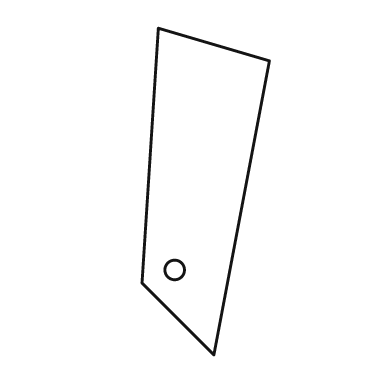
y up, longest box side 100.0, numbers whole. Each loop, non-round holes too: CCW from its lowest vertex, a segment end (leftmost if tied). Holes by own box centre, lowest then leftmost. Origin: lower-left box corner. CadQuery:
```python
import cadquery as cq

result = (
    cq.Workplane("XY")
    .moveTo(22.0, 0.0)
    .lineTo(39.0, 90.0)
    .lineTo(5.0, 100.0)
    .lineTo(0.0, 22.0)
    .close()
    .moveTo(10.0, 26.0)
    .circle(3.0)
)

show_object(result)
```